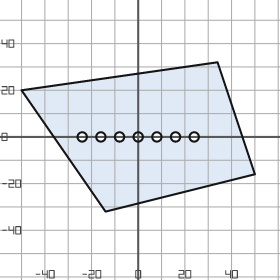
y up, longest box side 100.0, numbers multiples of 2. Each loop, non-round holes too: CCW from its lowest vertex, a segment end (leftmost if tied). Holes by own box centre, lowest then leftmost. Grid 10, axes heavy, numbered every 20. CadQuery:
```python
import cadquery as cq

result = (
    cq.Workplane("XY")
    .moveTo(-14.0, -32.0)
    .lineTo(50.0, -16.0)
    .lineTo(34.0, 32.0)
    .lineTo(-50.0, 20.0)
    .close()
    .moveTo(-24.0, 0.0)
    .circle(2.0)
    .moveTo(-16.0, 0.0)
    .circle(2.0)
    .moveTo(-8.0, 0.0)
    .circle(2.0)
    .moveTo(0.0, 0.0)
    .circle(2.0)
    .moveTo(8.0, 0.0)
    .circle(2.0)
    .moveTo(16.0, 0.0)
    .circle(2.0)
    .moveTo(24.0, 0.0)
    .circle(2.0)
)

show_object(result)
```